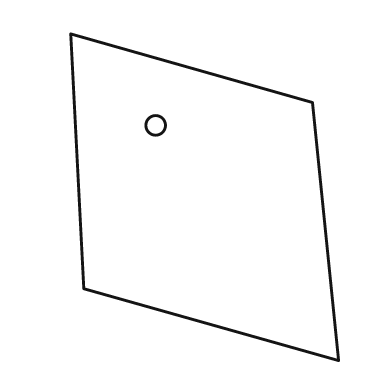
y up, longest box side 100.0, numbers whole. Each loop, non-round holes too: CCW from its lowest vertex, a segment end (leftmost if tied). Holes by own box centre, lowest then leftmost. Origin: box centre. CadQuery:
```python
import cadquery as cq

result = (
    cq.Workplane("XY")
    .moveTo(41.0, -50.0)
    .lineTo(33.0, 29.0)
    .lineTo(-41.0, 50.0)
    .lineTo(-37.0, -28.0)
    .close()
    .moveTo(-15.0, 22.0)
    .circle(3.0)
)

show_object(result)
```